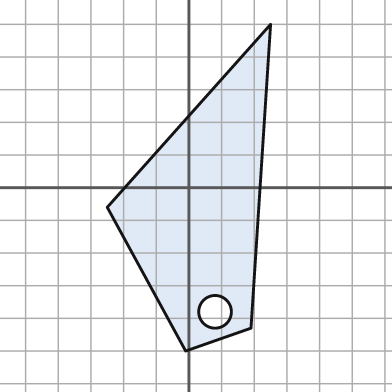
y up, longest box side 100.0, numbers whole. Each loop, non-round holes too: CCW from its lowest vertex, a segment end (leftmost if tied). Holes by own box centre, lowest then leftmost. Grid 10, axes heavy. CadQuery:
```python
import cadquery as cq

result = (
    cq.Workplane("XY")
    .moveTo(-1.0, -50.0)
    .lineTo(19.0, -43.0)
    .lineTo(25.0, 50.0)
    .lineTo(-25.0, -6.0)
    .close()
    .moveTo(8.0, -38.0)
    .circle(5.0)
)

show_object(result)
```